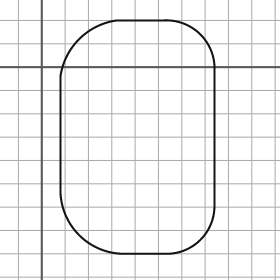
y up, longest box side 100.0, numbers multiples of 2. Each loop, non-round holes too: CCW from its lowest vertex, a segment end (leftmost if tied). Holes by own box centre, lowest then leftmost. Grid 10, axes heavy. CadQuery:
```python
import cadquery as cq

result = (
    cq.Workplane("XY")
    .moveTo(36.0, -80.0)
    .lineTo(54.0, -80.0)
    .threePointArc((68.0, -74.0), (74.0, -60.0))
    .lineTo(74.0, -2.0)
    .threePointArc((68.0, 14.0), (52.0, 20.0))
    .lineTo(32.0, 20.0)
    .threePointArc((16.0, 12.0), (8.0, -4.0))
    .lineTo(8.0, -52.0)
    .threePointArc((16.0, -72.0), (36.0, -80.0))
    .close()
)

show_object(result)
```